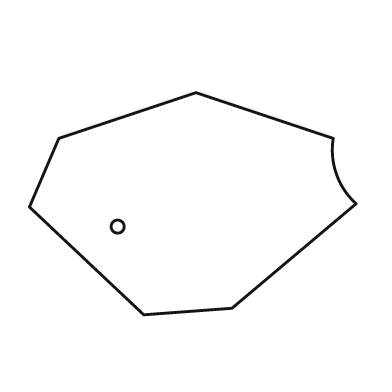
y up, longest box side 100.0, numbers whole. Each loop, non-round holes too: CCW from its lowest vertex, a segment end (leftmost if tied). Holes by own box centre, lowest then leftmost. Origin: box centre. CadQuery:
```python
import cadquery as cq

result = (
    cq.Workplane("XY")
    .moveTo(-15.0, -34.0)
    .lineTo(12.0, -32.0)
    .lineTo(50.0, 0.0)
    .threePointArc((44.0, 9.0), (43.0, 20.0))
    .lineTo(1.0, 34.0)
    .lineTo(-41.0, 20.0)
    .lineTo(-50.0, -1.0)
    .close()
    .moveTo(-23.0, -7.0)
    .circle(2.0)
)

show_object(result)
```